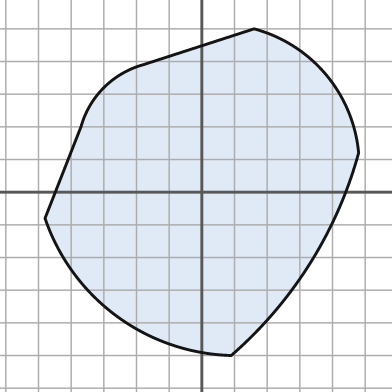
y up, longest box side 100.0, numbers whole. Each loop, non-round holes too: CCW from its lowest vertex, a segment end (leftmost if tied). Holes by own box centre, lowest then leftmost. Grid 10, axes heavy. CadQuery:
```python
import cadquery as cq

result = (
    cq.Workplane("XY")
    .moveTo(9.0, -50.0)
    .threePointArc((33.0, -22.0), (48.0, 12.0))
    .threePointArc((38.0, 36.0), (16.0, 50.0))
    .lineTo(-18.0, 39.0)
    .threePointArc((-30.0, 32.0), (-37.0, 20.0))
    .lineTo(-48.0, -8.0)
    .threePointArc((-26.0, -38.0), (9.0, -50.0))
    .close()
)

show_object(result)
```